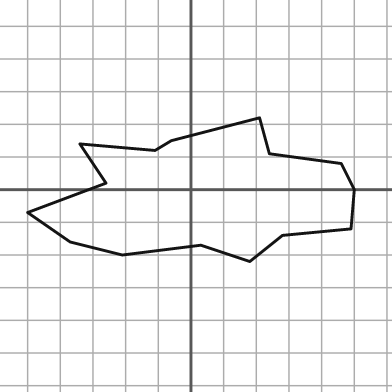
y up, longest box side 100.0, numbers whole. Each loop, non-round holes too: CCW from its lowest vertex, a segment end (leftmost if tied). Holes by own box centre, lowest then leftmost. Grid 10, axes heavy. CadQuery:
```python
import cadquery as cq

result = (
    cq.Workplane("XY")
    .moveTo(18.0, -22.0)
    .lineTo(28.0, -14.0)
    .lineTo(49.0, -12.0)
    .lineTo(50.0, 0.0)
    .lineTo(46.0, 8.0)
    .lineTo(24.0, 11.0)
    .lineTo(21.0, 22.0)
    .lineTo(-6.0, 15.0)
    .lineTo(-11.0, 12.0)
    .lineTo(-34.0, 14.0)
    .lineTo(-26.0, 2.0)
    .lineTo(-50.0, -7.0)
    .lineTo(-37.0, -16.0)
    .lineTo(-21.0, -20.0)
    .lineTo(3.0, -17.0)
    .close()
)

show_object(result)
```